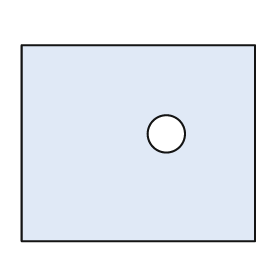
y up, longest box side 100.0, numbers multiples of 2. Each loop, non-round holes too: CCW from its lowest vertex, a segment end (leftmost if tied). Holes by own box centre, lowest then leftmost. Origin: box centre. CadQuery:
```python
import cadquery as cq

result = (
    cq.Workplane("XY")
    .moveTo(-50.0, -42.0)
    .lineTo(50.0, -42.0)
    .lineTo(50.0, 42.0)
    .lineTo(-50.0, 42.0)
    .close()
    .moveTo(12.0, 4.0)
    .circle(8.0)
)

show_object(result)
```